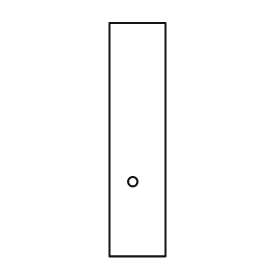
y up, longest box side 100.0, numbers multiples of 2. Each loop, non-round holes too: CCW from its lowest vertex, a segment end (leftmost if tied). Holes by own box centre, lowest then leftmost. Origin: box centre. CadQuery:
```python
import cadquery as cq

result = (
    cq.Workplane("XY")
    .moveTo(-12.0, -50.0)
    .lineTo(12.0, -50.0)
    .lineTo(12.0, 50.0)
    .lineTo(-12.0, 50.0)
    .close()
    .moveTo(-2.0, -18.0)
    .circle(2.0)
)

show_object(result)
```